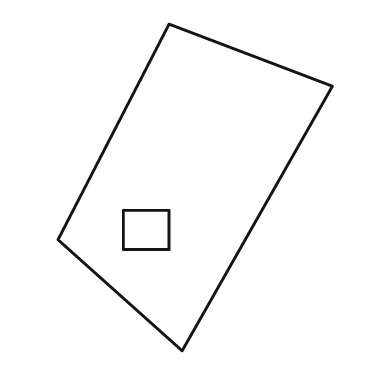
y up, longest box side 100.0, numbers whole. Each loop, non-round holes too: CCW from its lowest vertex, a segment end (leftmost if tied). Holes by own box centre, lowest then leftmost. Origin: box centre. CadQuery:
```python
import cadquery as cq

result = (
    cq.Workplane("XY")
    .moveTo(-4.0, -50.0)
    .lineTo(42.0, 31.0)
    .lineTo(-8.0, 50.0)
    .lineTo(-42.0, -16.0)
    .close()
    .moveTo(-22.0, -19.0)
    .lineTo(-8.0, -19.0)
    .lineTo(-8.0, -7.0)
    .lineTo(-22.0, -7.0)
    .close()
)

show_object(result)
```